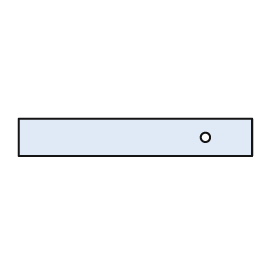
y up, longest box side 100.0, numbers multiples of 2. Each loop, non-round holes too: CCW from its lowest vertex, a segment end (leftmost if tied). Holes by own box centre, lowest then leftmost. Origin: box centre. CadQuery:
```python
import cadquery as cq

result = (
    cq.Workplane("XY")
    .moveTo(-50.0, -8.0)
    .lineTo(50.0, -8.0)
    .lineTo(50.0, 8.0)
    .lineTo(-50.0, 8.0)
    .close()
    .moveTo(30.0, 0.0)
    .circle(2.0)
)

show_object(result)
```